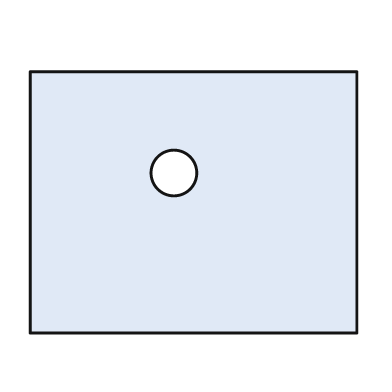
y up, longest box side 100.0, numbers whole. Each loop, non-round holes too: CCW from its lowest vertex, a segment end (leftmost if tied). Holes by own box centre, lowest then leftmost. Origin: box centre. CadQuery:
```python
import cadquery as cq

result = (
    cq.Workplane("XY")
    .moveTo(-50.0, -40.0)
    .lineTo(50.0, -40.0)
    .lineTo(50.0, 40.0)
    .lineTo(-50.0, 40.0)
    .close()
    .moveTo(-6.0, 9.0)
    .circle(7.0)
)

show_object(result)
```